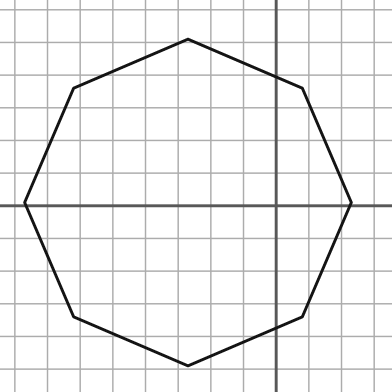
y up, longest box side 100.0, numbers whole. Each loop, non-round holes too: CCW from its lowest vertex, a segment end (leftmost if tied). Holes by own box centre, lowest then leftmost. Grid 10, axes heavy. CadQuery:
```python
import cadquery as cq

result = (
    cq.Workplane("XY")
    .moveTo(-27.0, -49.0)
    .lineTo(8.0, -34.0)
    .lineTo(23.0, 1.0)
    .lineTo(8.0, 36.0)
    .lineTo(-27.0, 51.0)
    .lineTo(-62.0, 36.0)
    .lineTo(-77.0, 1.0)
    .lineTo(-62.0, -34.0)
    .close()
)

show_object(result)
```